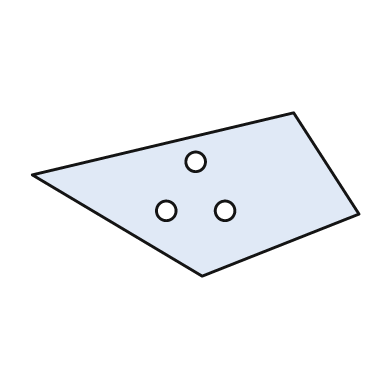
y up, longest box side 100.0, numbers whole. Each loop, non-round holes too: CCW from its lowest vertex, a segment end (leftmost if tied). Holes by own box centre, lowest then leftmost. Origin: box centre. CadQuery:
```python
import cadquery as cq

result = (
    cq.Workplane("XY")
    .moveTo(2.0, -25.0)
    .lineTo(50.0, -6.0)
    .lineTo(30.0, 25.0)
    .lineTo(-50.0, 6.0)
    .close()
    .moveTo(-9.0, -5.0)
    .circle(3.0)
    .moveTo(9.0, -5.0)
    .circle(3.0)
    .moveTo(0.0, 10.0)
    .circle(3.0)
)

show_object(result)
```